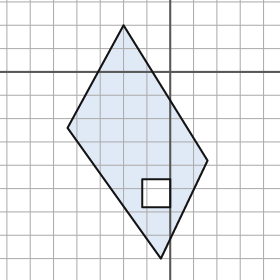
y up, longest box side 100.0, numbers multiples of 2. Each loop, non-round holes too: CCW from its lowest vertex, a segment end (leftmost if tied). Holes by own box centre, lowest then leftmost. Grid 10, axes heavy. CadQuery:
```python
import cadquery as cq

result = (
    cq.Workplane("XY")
    .moveTo(-4.0, -80.0)
    .lineTo(16.0, -38.0)
    .lineTo(-20.0, 20.0)
    .lineTo(-44.0, -24.0)
    .close()
    .moveTo(-12.0, -58.0)
    .lineTo(0.0, -58.0)
    .lineTo(0.0, -46.0)
    .lineTo(-12.0, -46.0)
    .close()
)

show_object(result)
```